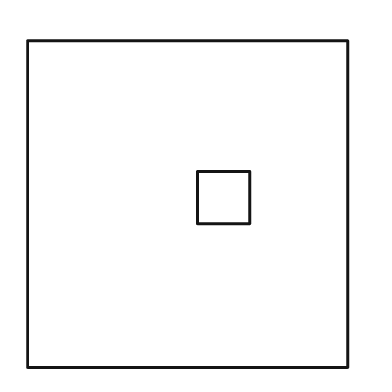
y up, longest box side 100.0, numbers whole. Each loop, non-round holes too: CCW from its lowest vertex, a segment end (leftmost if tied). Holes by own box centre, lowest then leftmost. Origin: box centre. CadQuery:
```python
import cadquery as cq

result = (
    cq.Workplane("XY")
    .moveTo(-49.0, -50.0)
    .lineTo(49.0, -50.0)
    .lineTo(49.0, 50.0)
    .lineTo(-49.0, 50.0)
    .close()
    .moveTo(3.0, -6.0)
    .lineTo(19.0, -6.0)
    .lineTo(19.0, 10.0)
    .lineTo(3.0, 10.0)
    .close()
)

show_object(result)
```